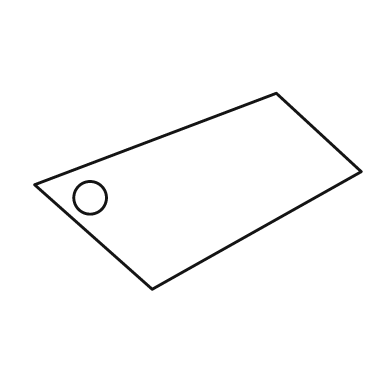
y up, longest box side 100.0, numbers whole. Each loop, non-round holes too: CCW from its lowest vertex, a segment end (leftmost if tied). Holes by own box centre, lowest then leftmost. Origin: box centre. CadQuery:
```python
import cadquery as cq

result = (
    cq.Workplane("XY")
    .moveTo(-14.0, -30.0)
    .lineTo(50.0, 6.0)
    .lineTo(24.0, 30.0)
    .lineTo(-50.0, 2.0)
    .close()
    .moveTo(-33.0, -2.0)
    .circle(5.0)
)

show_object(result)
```